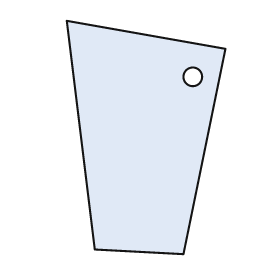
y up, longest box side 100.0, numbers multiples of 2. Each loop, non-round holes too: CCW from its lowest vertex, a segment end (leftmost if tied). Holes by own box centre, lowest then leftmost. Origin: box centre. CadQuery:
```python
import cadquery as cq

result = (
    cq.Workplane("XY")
    .moveTo(16.0, -50.0)
    .lineTo(34.0, 38.0)
    .lineTo(-34.0, 50.0)
    .lineTo(-22.0, -48.0)
    .close()
    .moveTo(20.0, 26.0)
    .circle(4.0)
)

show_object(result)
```